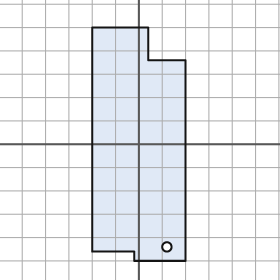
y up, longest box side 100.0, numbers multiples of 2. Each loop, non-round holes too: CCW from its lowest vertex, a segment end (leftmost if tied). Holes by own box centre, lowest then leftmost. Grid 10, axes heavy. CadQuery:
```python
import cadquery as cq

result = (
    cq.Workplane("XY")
    .moveTo(-2.0, -50.0)
    .lineTo(20.0, -50.0)
    .lineTo(20.0, 36.0)
    .lineTo(4.0, 36.0)
    .lineTo(4.0, 50.0)
    .lineTo(-20.0, 50.0)
    .lineTo(-20.0, -46.0)
    .lineTo(-2.0, -46.0)
    .close()
    .moveTo(12.0, -44.0)
    .circle(2.0)
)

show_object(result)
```